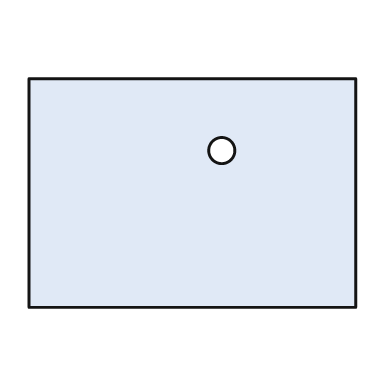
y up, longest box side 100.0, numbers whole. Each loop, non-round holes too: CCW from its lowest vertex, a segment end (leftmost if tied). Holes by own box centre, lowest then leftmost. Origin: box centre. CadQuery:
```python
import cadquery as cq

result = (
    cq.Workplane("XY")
    .moveTo(-50.0, -35.0)
    .lineTo(50.0, -35.0)
    .lineTo(50.0, 35.0)
    .lineTo(-50.0, 35.0)
    .close()
    .moveTo(9.0, 13.0)
    .circle(4.0)
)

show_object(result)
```